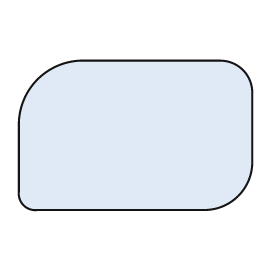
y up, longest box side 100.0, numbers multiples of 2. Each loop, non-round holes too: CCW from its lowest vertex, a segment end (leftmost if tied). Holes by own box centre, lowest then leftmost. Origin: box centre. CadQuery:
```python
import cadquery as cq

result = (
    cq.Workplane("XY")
    .moveTo(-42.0, -32.0)
    .lineTo(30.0, -32.0)
    .threePointArc((44.0, -26.0), (50.0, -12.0))
    .lineTo(50.0, 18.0)
    .threePointArc((46.0, 28.0), (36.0, 32.0))
    .lineTo(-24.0, 32.0)
    .threePointArc((-42.0, 24.0), (-50.0, 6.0))
    .lineTo(-50.0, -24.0)
    .threePointArc((-48.0, -30.0), (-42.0, -32.0))
    .close()
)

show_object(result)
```